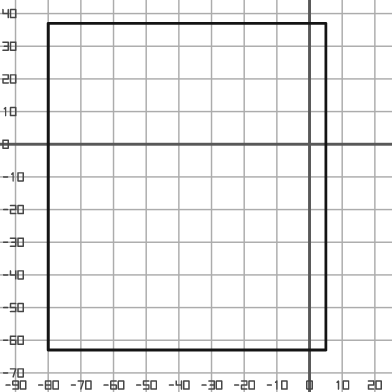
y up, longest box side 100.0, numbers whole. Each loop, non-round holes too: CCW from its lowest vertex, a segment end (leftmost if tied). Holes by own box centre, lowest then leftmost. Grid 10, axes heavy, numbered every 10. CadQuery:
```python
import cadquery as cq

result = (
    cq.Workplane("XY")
    .moveTo(-80.0, -63.0)
    .lineTo(5.0, -63.0)
    .lineTo(5.0, 37.0)
    .lineTo(-80.0, 37.0)
    .close()
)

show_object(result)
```